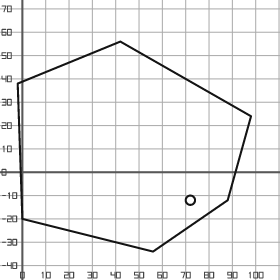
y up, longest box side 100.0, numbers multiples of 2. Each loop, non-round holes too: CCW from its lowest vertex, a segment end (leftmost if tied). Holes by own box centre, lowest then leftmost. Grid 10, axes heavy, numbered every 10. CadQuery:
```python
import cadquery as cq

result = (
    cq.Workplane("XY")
    .moveTo(56.0, -34.0)
    .lineTo(88.0, -12.0)
    .lineTo(98.0, 24.0)
    .lineTo(42.0, 56.0)
    .lineTo(-2.0, 38.0)
    .lineTo(0.0, -20.0)
    .close()
    .moveTo(72.0, -12.0)
    .circle(2.0)
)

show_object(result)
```